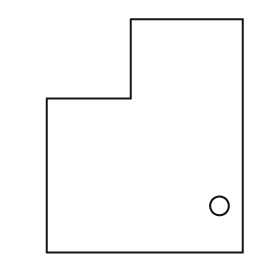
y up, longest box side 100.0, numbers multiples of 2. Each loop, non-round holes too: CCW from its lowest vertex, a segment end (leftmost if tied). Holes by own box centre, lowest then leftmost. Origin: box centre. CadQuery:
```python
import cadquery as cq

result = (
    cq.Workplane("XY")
    .moveTo(-42.0, -50.0)
    .lineTo(42.0, -50.0)
    .lineTo(42.0, 50.0)
    .lineTo(-6.0, 50.0)
    .lineTo(-6.0, 16.0)
    .lineTo(-42.0, 16.0)
    .close()
    .moveTo(32.0, -30.0)
    .circle(4.0)
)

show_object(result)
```